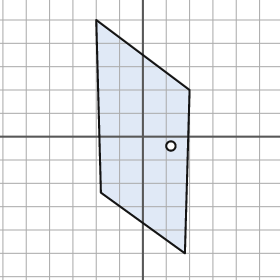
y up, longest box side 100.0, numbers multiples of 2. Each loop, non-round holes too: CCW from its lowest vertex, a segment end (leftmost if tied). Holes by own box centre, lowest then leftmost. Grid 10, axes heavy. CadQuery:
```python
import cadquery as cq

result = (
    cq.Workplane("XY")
    .moveTo(18.0, -50.0)
    .lineTo(20.0, 20.0)
    .lineTo(-20.0, 50.0)
    .lineTo(-18.0, -24.0)
    .close()
    .moveTo(12.0, -4.0)
    .circle(2.0)
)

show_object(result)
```